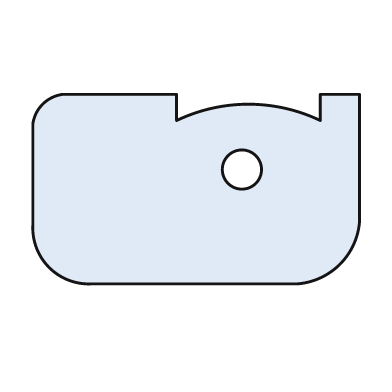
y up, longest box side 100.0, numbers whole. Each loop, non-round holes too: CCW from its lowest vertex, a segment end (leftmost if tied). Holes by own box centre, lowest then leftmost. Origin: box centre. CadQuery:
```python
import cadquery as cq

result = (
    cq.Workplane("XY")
    .moveTo(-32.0, -29.0)
    .lineTo(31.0, -29.0)
    .threePointArc((44.0, -23.0), (50.0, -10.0))
    .lineTo(50.0, 29.0)
    .lineTo(38.0, 29.0)
    .lineTo(38.0, 21.0)
    .threePointArc((16.0, 26.0), (-6.0, 21.0))
    .lineTo(-6.0, 29.0)
    .lineTo(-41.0, 29.0)
    .threePointArc((-47.0, 26.0), (-50.0, 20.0))
    .lineTo(-50.0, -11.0)
    .threePointArc((-45.0, -24.0), (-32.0, -29.0))
    .close()
    .moveTo(14.0, 6.0)
    .circle(6.0)
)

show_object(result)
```